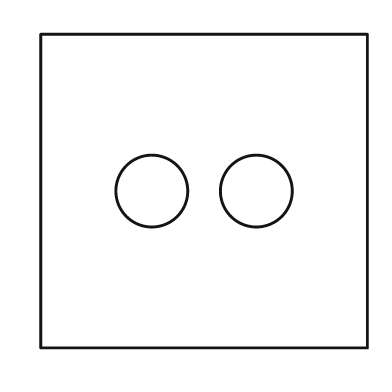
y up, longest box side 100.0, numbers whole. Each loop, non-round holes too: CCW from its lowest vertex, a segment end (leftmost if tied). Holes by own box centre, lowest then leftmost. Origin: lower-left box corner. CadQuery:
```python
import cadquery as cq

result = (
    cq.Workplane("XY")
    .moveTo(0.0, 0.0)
    .lineTo(100.0, 0.0)
    .lineTo(100.0, 96.0)
    .lineTo(0.0, 96.0)
    .close()
    .moveTo(34.0, 48.0)
    .circle(11.0)
    .moveTo(66.0, 48.0)
    .circle(11.0)
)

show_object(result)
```